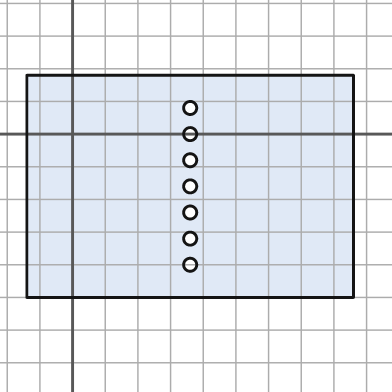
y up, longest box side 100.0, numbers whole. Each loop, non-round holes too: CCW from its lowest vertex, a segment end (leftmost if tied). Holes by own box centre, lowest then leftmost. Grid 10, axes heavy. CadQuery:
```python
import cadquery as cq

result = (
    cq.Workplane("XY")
    .moveTo(-14.0, -50.0)
    .lineTo(86.0, -50.0)
    .lineTo(86.0, 18.0)
    .lineTo(-14.0, 18.0)
    .close()
    .moveTo(36.0, -40.0)
    .circle(2.0)
    .moveTo(36.0, -32.0)
    .circle(2.0)
    .moveTo(36.0, -24.0)
    .circle(2.0)
    .moveTo(36.0, -16.0)
    .circle(2.0)
    .moveTo(36.0, -8.0)
    .circle(2.0)
    .moveTo(36.0, 0.0)
    .circle(2.0)
    .moveTo(36.0, 8.0)
    .circle(2.0)
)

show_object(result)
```